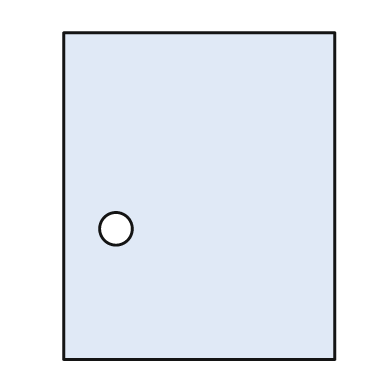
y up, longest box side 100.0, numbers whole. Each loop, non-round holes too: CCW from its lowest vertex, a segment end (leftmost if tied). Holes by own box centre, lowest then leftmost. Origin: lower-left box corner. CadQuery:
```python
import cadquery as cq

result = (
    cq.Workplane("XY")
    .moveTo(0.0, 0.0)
    .lineTo(83.0, 0.0)
    .lineTo(83.0, 100.0)
    .lineTo(0.0, 100.0)
    .close()
    .moveTo(16.0, 40.0)
    .circle(5.0)
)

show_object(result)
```